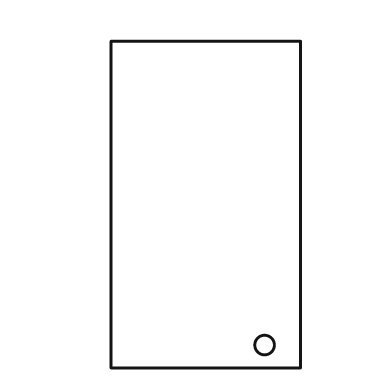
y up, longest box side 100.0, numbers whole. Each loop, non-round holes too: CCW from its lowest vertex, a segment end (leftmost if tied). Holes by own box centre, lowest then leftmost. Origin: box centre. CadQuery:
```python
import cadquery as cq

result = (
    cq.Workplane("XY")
    .moveTo(-29.0, -50.0)
    .lineTo(29.0, -50.0)
    .lineTo(29.0, 50.0)
    .lineTo(-29.0, 50.0)
    .close()
    .moveTo(18.0, -43.0)
    .circle(3.0)
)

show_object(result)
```